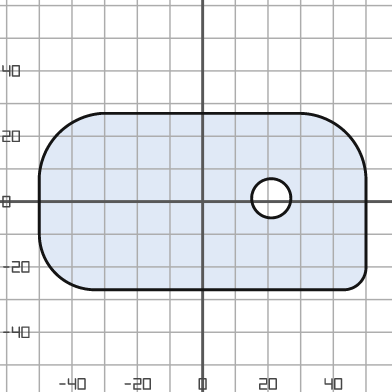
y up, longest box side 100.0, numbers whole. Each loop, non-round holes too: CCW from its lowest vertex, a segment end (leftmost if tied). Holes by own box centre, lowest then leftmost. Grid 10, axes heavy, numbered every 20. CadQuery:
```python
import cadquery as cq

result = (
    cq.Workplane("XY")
    .moveTo(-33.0, -27.0)
    .lineTo(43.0, -27.0)
    .threePointArc((48.0, -25.0), (50.0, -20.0))
    .lineTo(50.0, 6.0)
    .threePointArc((44.0, 21.0), (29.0, 27.0))
    .lineTo(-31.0, 27.0)
    .threePointArc((-44.0, 21.0), (-50.0, 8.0))
    .lineTo(-50.0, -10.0)
    .threePointArc((-45.0, -22.0), (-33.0, -27.0))
    .close()
    .moveTo(21.0, 1.0)
    .circle(6.0)
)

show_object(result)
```